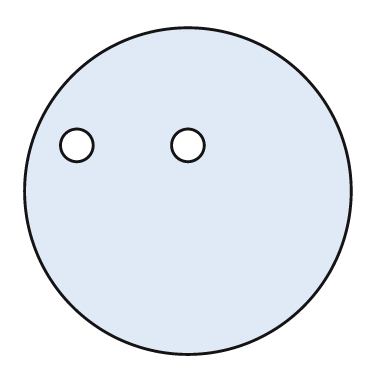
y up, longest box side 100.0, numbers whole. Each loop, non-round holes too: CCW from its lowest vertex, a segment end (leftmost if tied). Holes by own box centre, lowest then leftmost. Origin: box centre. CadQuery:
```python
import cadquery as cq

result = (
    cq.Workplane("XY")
    .moveTo(0.0, 0.0)
    .circle(50.0)
    .moveTo(-34.0, 14.0)
    .circle(5.0)
    .moveTo(0.0, 14.0)
    .circle(5.0)
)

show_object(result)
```